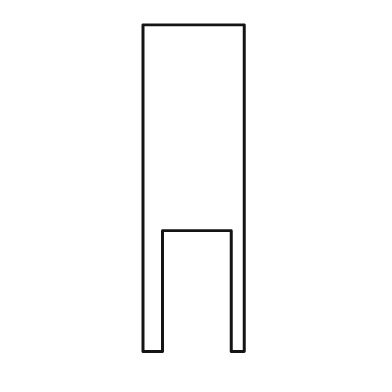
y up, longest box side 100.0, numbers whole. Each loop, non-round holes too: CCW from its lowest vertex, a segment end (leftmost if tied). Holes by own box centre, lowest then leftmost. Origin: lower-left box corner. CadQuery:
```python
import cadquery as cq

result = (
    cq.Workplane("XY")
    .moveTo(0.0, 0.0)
    .lineTo(6.0, 0.0)
    .lineTo(6.0, 37.0)
    .lineTo(27.0, 37.0)
    .lineTo(27.0, 0.0)
    .lineTo(31.0, 0.0)
    .lineTo(31.0, 100.0)
    .lineTo(0.0, 100.0)
    .close()
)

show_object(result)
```